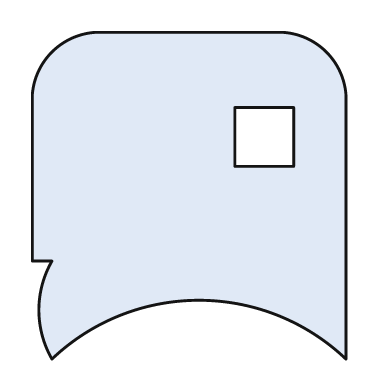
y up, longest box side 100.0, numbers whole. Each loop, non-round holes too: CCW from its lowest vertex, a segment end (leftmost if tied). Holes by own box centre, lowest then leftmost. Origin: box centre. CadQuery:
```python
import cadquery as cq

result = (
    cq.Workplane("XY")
    .moveTo(-42.0, -50.0)
    .threePointArc((3.0, -32.0), (48.0, -50.0))
    .lineTo(48.0, 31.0)
    .threePointArc((42.0, 44.0), (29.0, 50.0))
    .lineTo(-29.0, 50.0)
    .threePointArc((-42.0, 44.0), (-48.0, 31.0))
    .lineTo(-48.0, -20.0)
    .lineTo(-42.0, -20.0)
    .threePointArc((-46.0, -35.0), (-42.0, -50.0))
    .close()
    .moveTo(14.0, 9.0)
    .lineTo(32.0, 9.0)
    .lineTo(32.0, 27.0)
    .lineTo(14.0, 27.0)
    .close()
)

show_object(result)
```